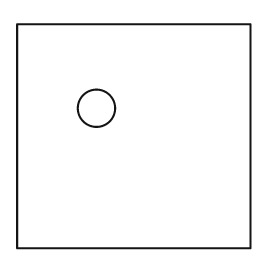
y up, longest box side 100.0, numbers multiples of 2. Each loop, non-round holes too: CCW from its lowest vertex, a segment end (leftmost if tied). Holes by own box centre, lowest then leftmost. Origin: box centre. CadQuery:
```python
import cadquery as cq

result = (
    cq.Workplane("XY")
    .moveTo(-50.0, -48.0)
    .lineTo(50.0, -48.0)
    .lineTo(50.0, 48.0)
    .lineTo(-50.0, 48.0)
    .close()
    .moveTo(-16.0, 12.0)
    .circle(8.0)
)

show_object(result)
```